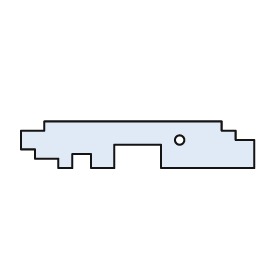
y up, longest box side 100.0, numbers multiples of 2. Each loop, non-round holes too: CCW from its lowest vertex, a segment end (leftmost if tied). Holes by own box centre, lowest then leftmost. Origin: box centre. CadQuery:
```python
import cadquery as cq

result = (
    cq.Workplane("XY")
    .moveTo(-34.0, -10.0)
    .lineTo(-28.0, -10.0)
    .lineTo(-28.0, -4.0)
    .lineTo(-20.0, -4.0)
    .lineTo(-20.0, -10.0)
    .lineTo(-10.0, -10.0)
    .lineTo(-10.0, 0.0)
    .lineTo(10.0, 0.0)
    .lineTo(10.0, -10.0)
    .lineTo(50.0, -10.0)
    .lineTo(50.0, 2.0)
    .lineTo(42.0, 2.0)
    .lineTo(42.0, 6.0)
    .lineTo(36.0, 6.0)
    .lineTo(36.0, 10.0)
    .lineTo(-40.0, 10.0)
    .lineTo(-40.0, 6.0)
    .lineTo(-50.0, 6.0)
    .lineTo(-50.0, -2.0)
    .lineTo(-44.0, -2.0)
    .lineTo(-44.0, -6.0)
    .lineTo(-34.0, -6.0)
    .close()
    .moveTo(18.0, 2.0)
    .circle(2.0)
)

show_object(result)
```